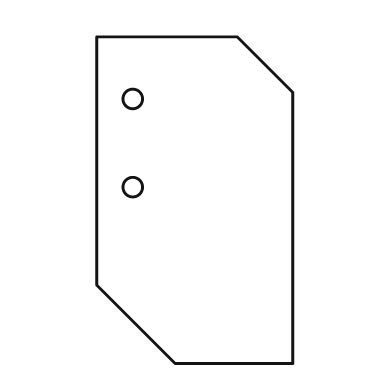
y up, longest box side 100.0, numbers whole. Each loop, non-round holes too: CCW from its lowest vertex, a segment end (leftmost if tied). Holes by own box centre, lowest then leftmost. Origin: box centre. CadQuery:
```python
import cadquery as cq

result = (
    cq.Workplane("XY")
    .moveTo(-6.0, -50.0)
    .lineTo(30.0, -50.0)
    .lineTo(30.0, 33.0)
    .lineTo(13.0, 50.0)
    .lineTo(-30.0, 50.0)
    .lineTo(-30.0, -26.0)
    .close()
    .moveTo(-19.0, 4.0)
    .circle(3.0)
    .moveTo(-19.0, 31.0)
    .circle(3.0)
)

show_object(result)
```